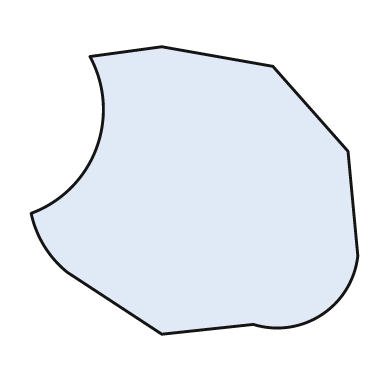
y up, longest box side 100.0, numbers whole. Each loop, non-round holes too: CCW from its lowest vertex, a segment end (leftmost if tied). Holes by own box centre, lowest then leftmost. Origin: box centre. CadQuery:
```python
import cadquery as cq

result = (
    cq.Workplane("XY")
    .moveTo(-10.0, -44.0)
    .lineTo(18.0, -41.0)
    .threePointArc((39.0, -38.0), (50.0, -20.0))
    .lineTo(47.0, 12.0)
    .lineTo(24.0, 38.0)
    .lineTo(-10.0, 44.0)
    .lineTo(-32.0, 41.0)
    .threePointArc((-30.0, 13.0), (-50.0, -7.0))
    .threePointArc((-46.0, -17.0), (-39.0, -25.0))
    .close()
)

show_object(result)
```